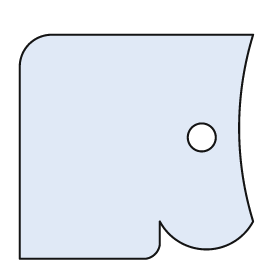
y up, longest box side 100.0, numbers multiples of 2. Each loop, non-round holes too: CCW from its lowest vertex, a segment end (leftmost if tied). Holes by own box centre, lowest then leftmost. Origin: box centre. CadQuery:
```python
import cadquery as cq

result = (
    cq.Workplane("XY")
    .moveTo(-50.0, -48.0)
    .lineTo(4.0, -48.0)
    .threePointArc((8.0, -46.0), (10.0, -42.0))
    .lineTo(10.0, -32.0)
    .threePointArc((30.0, -44.0), (50.0, -32.0))
    .threePointArc((44.0, 8.0), (50.0, 48.0))
    .lineTo(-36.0, 48.0)
    .threePointArc((-46.0, 44.0), (-50.0, 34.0))
    .close()
    .moveTo(28.0, 4.0)
    .circle(6.0)
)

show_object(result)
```